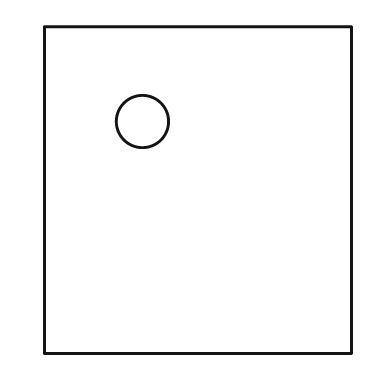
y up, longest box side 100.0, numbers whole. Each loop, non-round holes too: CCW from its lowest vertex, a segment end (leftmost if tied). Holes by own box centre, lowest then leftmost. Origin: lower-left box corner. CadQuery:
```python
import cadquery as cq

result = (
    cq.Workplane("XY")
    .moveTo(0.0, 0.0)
    .lineTo(94.0, 0.0)
    .lineTo(94.0, 100.0)
    .lineTo(0.0, 100.0)
    .close()
    .moveTo(30.0, 71.0)
    .circle(8.0)
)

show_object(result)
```